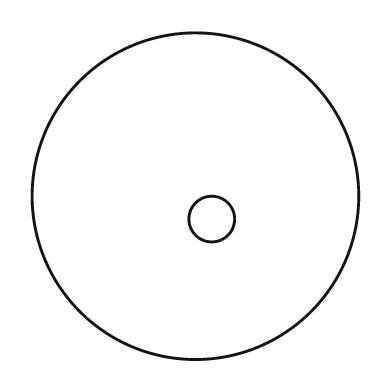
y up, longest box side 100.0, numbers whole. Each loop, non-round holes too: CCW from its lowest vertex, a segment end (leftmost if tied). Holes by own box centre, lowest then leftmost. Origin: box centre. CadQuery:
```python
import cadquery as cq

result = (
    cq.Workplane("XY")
    .moveTo(0.0, 0.0)
    .circle(50.0)
    .moveTo(5.0, -7.0)
    .circle(7.0)
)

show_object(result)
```